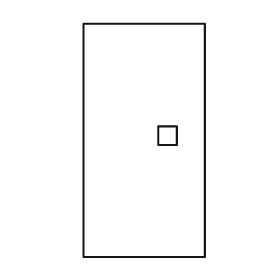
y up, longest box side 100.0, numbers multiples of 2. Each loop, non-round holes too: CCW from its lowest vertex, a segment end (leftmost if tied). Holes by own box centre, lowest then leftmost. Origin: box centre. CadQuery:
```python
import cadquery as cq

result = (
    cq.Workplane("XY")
    .moveTo(-26.0, -50.0)
    .lineTo(26.0, -50.0)
    .lineTo(26.0, 50.0)
    .lineTo(-26.0, 50.0)
    .close()
    .moveTo(6.0, -2.0)
    .lineTo(14.0, -2.0)
    .lineTo(14.0, 6.0)
    .lineTo(6.0, 6.0)
    .close()
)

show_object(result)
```